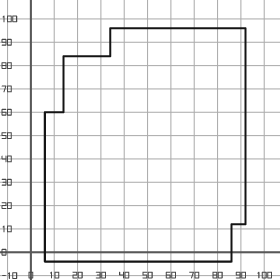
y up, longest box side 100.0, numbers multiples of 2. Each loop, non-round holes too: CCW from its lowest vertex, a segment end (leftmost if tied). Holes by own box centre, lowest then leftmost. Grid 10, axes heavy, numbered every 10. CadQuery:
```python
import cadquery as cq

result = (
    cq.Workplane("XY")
    .moveTo(6.0, -4.0)
    .lineTo(86.0, -4.0)
    .lineTo(86.0, 12.0)
    .lineTo(92.0, 12.0)
    .lineTo(92.0, 96.0)
    .lineTo(34.0, 96.0)
    .lineTo(34.0, 84.0)
    .lineTo(14.0, 84.0)
    .lineTo(14.0, 60.0)
    .lineTo(6.0, 60.0)
    .close()
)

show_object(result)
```